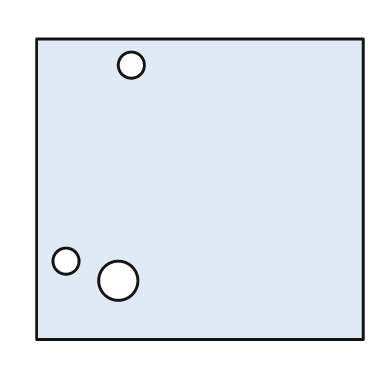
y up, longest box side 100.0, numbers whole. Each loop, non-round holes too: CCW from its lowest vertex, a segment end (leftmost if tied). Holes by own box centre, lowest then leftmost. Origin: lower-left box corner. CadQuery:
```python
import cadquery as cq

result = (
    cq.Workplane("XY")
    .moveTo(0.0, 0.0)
    .lineTo(100.0, 0.0)
    .lineTo(100.0, 92.0)
    .lineTo(0.0, 92.0)
    .close()
    .moveTo(25.0, 18.0)
    .circle(6.0)
    .moveTo(9.0, 24.0)
    .circle(4.0)
    .moveTo(29.0, 84.0)
    .circle(4.0)
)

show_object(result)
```